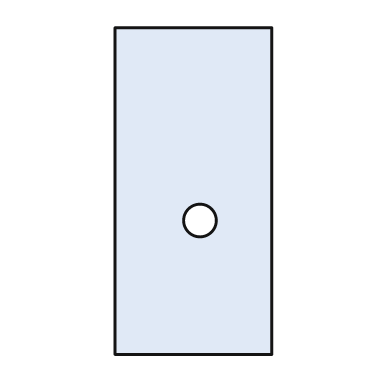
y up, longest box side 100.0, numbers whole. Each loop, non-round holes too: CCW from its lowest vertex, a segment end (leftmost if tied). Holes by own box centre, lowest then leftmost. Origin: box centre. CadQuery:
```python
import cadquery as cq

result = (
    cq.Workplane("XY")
    .moveTo(-24.0, -50.0)
    .lineTo(24.0, -50.0)
    .lineTo(24.0, 50.0)
    .lineTo(-24.0, 50.0)
    .close()
    .moveTo(2.0, -9.0)
    .circle(5.0)
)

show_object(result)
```